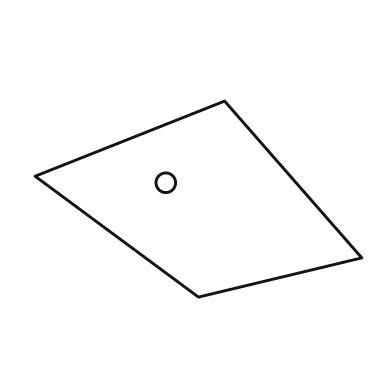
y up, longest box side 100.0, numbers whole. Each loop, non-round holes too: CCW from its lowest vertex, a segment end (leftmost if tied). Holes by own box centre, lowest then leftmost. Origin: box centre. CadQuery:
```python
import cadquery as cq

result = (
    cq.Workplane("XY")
    .moveTo(0.0, -30.0)
    .lineTo(50.0, -18.0)
    .lineTo(8.0, 30.0)
    .lineTo(-50.0, 7.0)
    .close()
    .moveTo(-10.0, 5.0)
    .circle(3.0)
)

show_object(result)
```